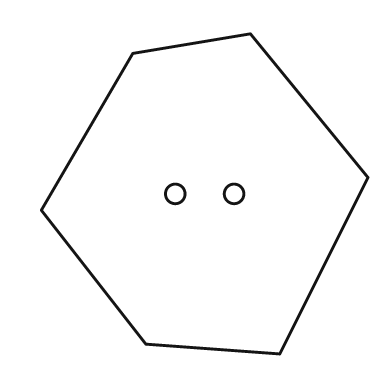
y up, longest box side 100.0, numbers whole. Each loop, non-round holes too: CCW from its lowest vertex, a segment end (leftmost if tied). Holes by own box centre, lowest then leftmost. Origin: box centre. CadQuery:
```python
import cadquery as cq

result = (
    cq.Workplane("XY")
    .moveTo(23.0, -49.0)
    .lineTo(50.0, 5.0)
    .lineTo(14.0, 49.0)
    .lineTo(-22.0, 43.0)
    .lineTo(-50.0, -5.0)
    .lineTo(-18.0, -46.0)
    .close()
    .moveTo(-9.0, 0.0)
    .circle(3.0)
    .moveTo(9.0, 0.0)
    .circle(3.0)
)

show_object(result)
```